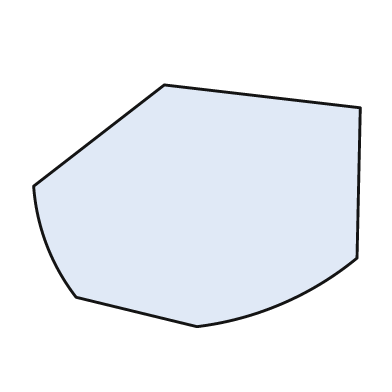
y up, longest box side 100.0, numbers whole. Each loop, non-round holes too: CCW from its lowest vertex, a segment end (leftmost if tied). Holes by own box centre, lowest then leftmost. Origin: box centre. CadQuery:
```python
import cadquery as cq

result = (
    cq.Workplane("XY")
    .moveTo(0.0, -37.0)
    .threePointArc((26.0, -30.0), (49.0, -16.0))
    .lineTo(50.0, 30.0)
    .lineTo(-10.0, 37.0)
    .lineTo(-50.0, 6.0)
    .threePointArc((-46.0, -12.0), (-37.0, -28.0))
    .close()
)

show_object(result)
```